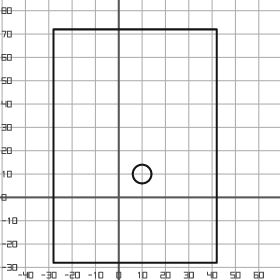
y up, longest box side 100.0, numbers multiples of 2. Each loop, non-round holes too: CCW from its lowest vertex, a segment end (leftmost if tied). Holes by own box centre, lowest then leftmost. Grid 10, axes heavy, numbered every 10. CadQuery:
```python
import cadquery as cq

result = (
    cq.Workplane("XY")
    .moveTo(-28.0, -28.0)
    .lineTo(42.0, -28.0)
    .lineTo(42.0, 72.0)
    .lineTo(-28.0, 72.0)
    .close()
    .moveTo(10.0, 10.0)
    .circle(4.0)
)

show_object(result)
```